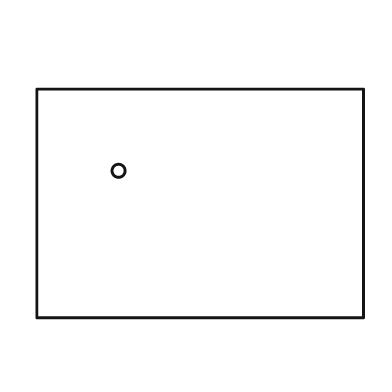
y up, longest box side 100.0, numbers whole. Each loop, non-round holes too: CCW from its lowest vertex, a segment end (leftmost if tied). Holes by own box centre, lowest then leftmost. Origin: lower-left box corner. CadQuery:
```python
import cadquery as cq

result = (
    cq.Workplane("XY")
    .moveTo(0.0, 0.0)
    .lineTo(100.0, 0.0)
    .lineTo(100.0, 70.0)
    .lineTo(0.0, 70.0)
    .close()
    .moveTo(25.0, 45.0)
    .circle(2.0)
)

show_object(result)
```